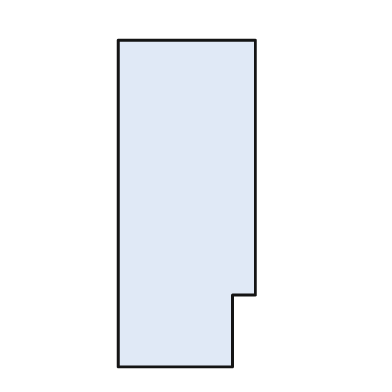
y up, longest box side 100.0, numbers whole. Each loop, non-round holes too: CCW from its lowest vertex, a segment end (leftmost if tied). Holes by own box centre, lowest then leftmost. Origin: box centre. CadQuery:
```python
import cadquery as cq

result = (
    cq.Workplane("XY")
    .moveTo(-21.0, -50.0)
    .lineTo(14.0, -50.0)
    .lineTo(14.0, -28.0)
    .lineTo(21.0, -28.0)
    .lineTo(21.0, 50.0)
    .lineTo(-21.0, 50.0)
    .close()
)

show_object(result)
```